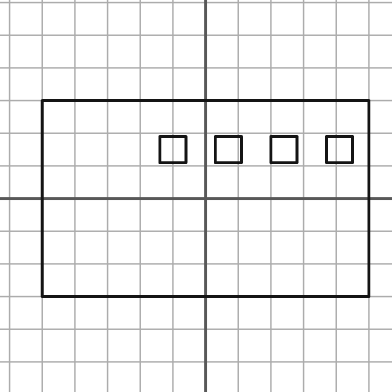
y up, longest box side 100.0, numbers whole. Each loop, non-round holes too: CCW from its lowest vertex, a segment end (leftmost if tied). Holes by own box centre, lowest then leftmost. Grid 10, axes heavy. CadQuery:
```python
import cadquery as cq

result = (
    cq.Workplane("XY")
    .moveTo(-50.0, -30.0)
    .lineTo(50.0, -30.0)
    .lineTo(50.0, 30.0)
    .lineTo(-50.0, 30.0)
    .close()
    .moveTo(-14.0, 11.0)
    .lineTo(-6.0, 11.0)
    .lineTo(-6.0, 19.0)
    .lineTo(-14.0, 19.0)
    .close()
    .moveTo(3.0, 11.0)
    .lineTo(11.0, 11.0)
    .lineTo(11.0, 19.0)
    .lineTo(3.0, 19.0)
    .close()
    .moveTo(20.0, 11.0)
    .lineTo(28.0, 11.0)
    .lineTo(28.0, 19.0)
    .lineTo(20.0, 19.0)
    .close()
    .moveTo(37.0, 11.0)
    .lineTo(45.0, 11.0)
    .lineTo(45.0, 19.0)
    .lineTo(37.0, 19.0)
    .close()
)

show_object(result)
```